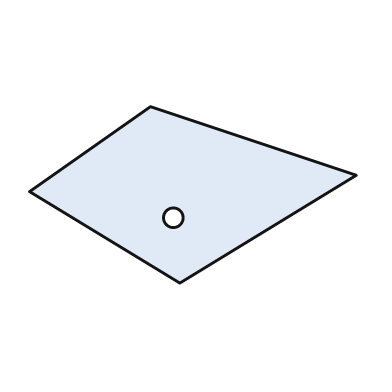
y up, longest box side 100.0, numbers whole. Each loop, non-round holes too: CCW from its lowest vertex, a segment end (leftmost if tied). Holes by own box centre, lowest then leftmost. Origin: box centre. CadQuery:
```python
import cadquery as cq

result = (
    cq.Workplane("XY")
    .moveTo(-4.0, -27.0)
    .lineTo(50.0, 6.0)
    .lineTo(-13.0, 27.0)
    .lineTo(-50.0, 1.0)
    .close()
    .moveTo(-6.0, -7.0)
    .circle(3.0)
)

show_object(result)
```